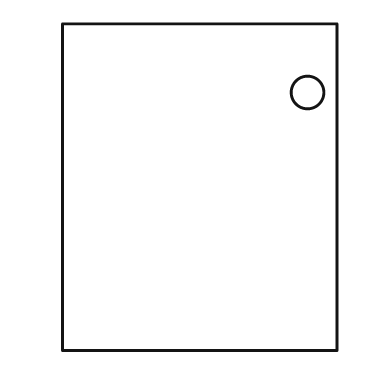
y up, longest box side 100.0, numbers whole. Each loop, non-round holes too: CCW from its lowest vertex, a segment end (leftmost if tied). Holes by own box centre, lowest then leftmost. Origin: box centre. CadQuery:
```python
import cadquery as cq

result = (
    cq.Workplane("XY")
    .moveTo(-42.0, -50.0)
    .lineTo(42.0, -50.0)
    .lineTo(42.0, 50.0)
    .lineTo(-42.0, 50.0)
    .close()
    .moveTo(33.0, 29.0)
    .circle(5.0)
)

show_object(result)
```